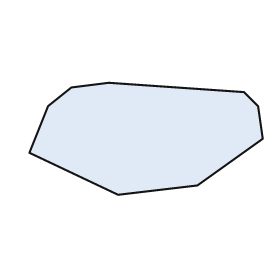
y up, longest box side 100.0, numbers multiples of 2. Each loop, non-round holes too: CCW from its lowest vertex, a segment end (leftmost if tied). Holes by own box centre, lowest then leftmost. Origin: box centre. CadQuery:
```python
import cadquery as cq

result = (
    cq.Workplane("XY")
    .moveTo(-12.0, -24.0)
    .lineTo(22.0, -20.0)
    .lineTo(50.0, 0.0)
    .lineTo(48.0, 14.0)
    .lineTo(42.0, 20.0)
    .lineTo(-16.0, 24.0)
    .lineTo(-32.0, 22.0)
    .lineTo(-42.0, 14.0)
    .lineTo(-50.0, -6.0)
    .close()
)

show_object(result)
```